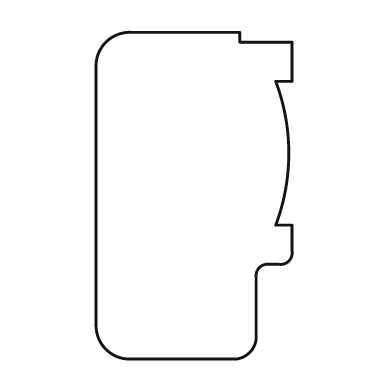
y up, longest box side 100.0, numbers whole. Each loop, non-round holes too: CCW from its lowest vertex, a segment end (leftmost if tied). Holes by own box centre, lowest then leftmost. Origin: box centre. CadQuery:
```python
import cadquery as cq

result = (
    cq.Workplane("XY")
    .moveTo(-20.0, -50.0)
    .lineTo(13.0, -50.0)
    .threePointArc((17.0, -48.0), (19.0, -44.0))
    .lineTo(19.0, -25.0)
    .threePointArc((20.0, -22.0), (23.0, -21.0))
    .lineTo(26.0, -21.0)
    .threePointArc((29.0, -20.0), (30.0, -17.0))
    .lineTo(30.0, -9.0)
    .lineTo(25.0, -9.0)
    .threePointArc((29.0, 13.0), (25.0, 35.0))
    .lineTo(30.0, 35.0)
    .lineTo(30.0, 47.0)
    .lineTo(14.0, 47.0)
    .lineTo(14.0, 50.0)
    .lineTo(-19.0, 50.0)
    .threePointArc((-27.0, 47.0), (-30.0, 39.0))
    .lineTo(-30.0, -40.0)
    .threePointArc((-27.0, -47.0), (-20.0, -50.0))
    .close()
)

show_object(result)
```